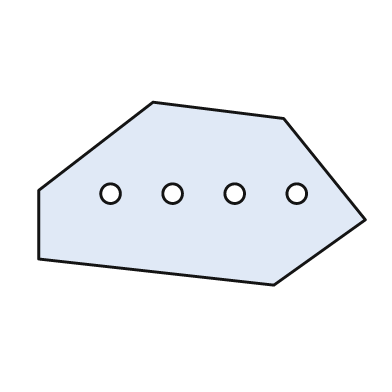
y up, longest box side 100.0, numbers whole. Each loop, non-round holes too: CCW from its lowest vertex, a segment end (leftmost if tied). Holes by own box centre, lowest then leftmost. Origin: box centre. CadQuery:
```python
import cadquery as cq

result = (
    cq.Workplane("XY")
    .moveTo(22.0, -28.0)
    .lineTo(50.0, -8.0)
    .lineTo(25.0, 23.0)
    .lineTo(-15.0, 28.0)
    .lineTo(-50.0, 1.0)
    .lineTo(-50.0, -20.0)
    .close()
    .moveTo(-28.0, 0.0)
    .circle(3.0)
    .moveTo(-9.0, 0.0)
    .circle(3.0)
    .moveTo(10.0, 0.0)
    .circle(3.0)
    .moveTo(29.0, 0.0)
    .circle(3.0)
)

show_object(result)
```